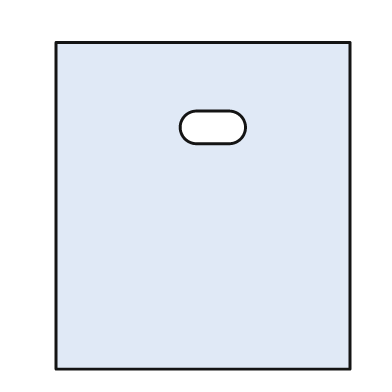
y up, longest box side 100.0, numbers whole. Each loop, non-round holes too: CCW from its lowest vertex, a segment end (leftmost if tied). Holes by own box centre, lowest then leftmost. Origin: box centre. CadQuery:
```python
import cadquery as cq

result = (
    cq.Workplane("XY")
    .moveTo(-45.0, -50.0)
    .lineTo(45.0, -50.0)
    .lineTo(45.0, 50.0)
    .lineTo(-45.0, 50.0)
    .close()
    .moveTo(-2.0, 19.0)
    .lineTo(8.0, 19.0)
    .threePointArc((13.0, 24.0), (8.0, 29.0))
    .lineTo(-2.0, 29.0)
    .threePointArc((-7.0, 24.0), (-2.0, 19.0))
    .close()
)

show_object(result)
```